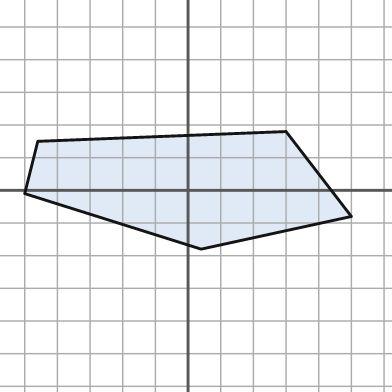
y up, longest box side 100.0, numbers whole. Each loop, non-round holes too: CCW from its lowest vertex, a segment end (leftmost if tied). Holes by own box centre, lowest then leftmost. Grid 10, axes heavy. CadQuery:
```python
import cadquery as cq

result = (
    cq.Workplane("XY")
    .moveTo(4.0, -18.0)
    .lineTo(50.0, -8.0)
    .lineTo(30.0, 18.0)
    .lineTo(-46.0, 15.0)
    .lineTo(-50.0, -1.0)
    .close()
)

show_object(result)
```